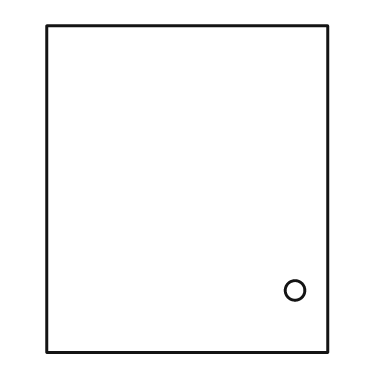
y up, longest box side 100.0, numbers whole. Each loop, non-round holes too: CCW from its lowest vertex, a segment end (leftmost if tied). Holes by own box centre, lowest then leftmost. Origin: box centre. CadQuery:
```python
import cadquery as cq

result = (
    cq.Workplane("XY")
    .moveTo(-43.0, -50.0)
    .lineTo(43.0, -50.0)
    .lineTo(43.0, 50.0)
    .lineTo(-43.0, 50.0)
    .close()
    .moveTo(33.0, -31.0)
    .circle(3.0)
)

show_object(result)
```